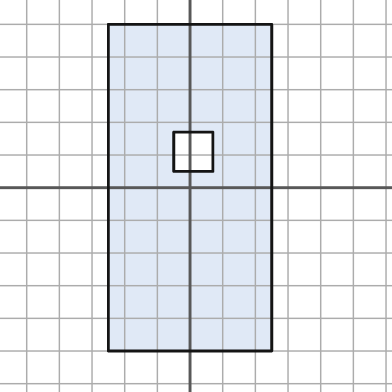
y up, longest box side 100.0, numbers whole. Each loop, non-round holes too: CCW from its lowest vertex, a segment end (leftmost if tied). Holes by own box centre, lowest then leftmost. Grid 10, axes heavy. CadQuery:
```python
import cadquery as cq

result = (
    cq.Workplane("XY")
    .moveTo(-25.0, -50.0)
    .lineTo(25.0, -50.0)
    .lineTo(25.0, 50.0)
    .lineTo(-25.0, 50.0)
    .close()
    .moveTo(-5.0, 5.0)
    .lineTo(7.0, 5.0)
    .lineTo(7.0, 17.0)
    .lineTo(-5.0, 17.0)
    .close()
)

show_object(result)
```